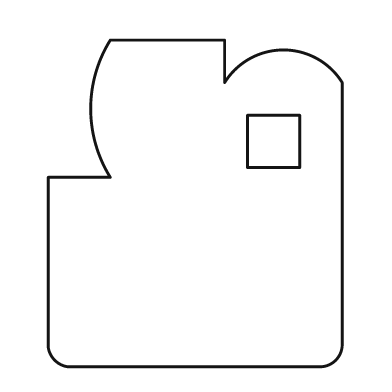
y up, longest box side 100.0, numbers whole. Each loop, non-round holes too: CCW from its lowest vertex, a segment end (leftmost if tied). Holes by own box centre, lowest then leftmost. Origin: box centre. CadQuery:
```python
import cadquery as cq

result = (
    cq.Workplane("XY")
    .moveTo(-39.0, -50.0)
    .lineTo(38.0, -50.0)
    .threePointArc((43.0, -48.0), (45.0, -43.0))
    .lineTo(45.0, 37.0)
    .threePointArc((27.0, 47.0), (9.0, 37.0))
    .lineTo(9.0, 50.0)
    .lineTo(-26.0, 50.0)
    .threePointArc((-32.0, 29.0), (-26.0, 8.0))
    .lineTo(-45.0, 8.0)
    .lineTo(-45.0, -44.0)
    .threePointArc((-43.0, -48.0), (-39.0, -50.0))
    .close()
    .moveTo(16.0, 11.0)
    .lineTo(32.0, 11.0)
    .lineTo(32.0, 27.0)
    .lineTo(16.0, 27.0)
    .close()
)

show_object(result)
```